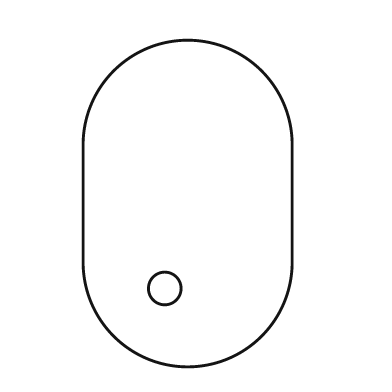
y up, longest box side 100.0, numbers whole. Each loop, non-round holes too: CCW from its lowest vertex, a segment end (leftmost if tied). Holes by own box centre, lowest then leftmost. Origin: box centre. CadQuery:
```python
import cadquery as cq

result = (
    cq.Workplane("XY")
    .moveTo(-32.0, -18.0)
    .threePointArc((0.0, -50.0), (32.0, -18.0))
    .lineTo(32.0, 18.0)
    .threePointArc((0.0, 50.0), (-32.0, 18.0))
    .close()
    .moveTo(-7.0, -26.0)
    .circle(5.0)
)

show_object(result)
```